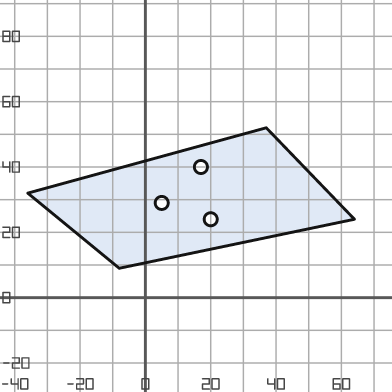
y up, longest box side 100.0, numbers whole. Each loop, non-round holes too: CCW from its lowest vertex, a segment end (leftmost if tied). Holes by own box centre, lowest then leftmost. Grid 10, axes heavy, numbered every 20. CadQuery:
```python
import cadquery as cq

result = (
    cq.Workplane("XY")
    .moveTo(-8.0, 9.0)
    .lineTo(64.0, 24.0)
    .lineTo(37.0, 52.0)
    .lineTo(-36.0, 32.0)
    .close()
    .moveTo(20.0, 24.0)
    .circle(2.0)
    .moveTo(5.0, 29.0)
    .circle(2.0)
    .moveTo(17.0, 40.0)
    .circle(2.0)
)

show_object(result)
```